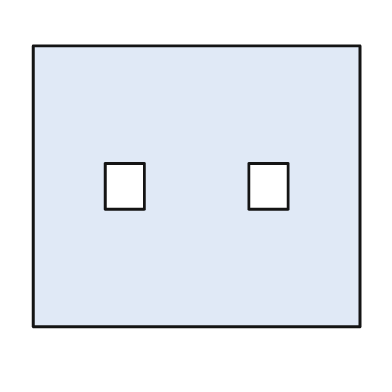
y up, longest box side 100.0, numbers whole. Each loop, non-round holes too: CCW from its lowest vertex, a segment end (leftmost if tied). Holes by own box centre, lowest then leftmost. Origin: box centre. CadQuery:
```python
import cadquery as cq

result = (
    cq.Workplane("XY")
    .moveTo(-50.0, -43.0)
    .lineTo(50.0, -43.0)
    .lineTo(50.0, 43.0)
    .lineTo(-50.0, 43.0)
    .close()
    .moveTo(-28.0, -7.0)
    .lineTo(-16.0, -7.0)
    .lineTo(-16.0, 7.0)
    .lineTo(-28.0, 7.0)
    .close()
    .moveTo(16.0, -7.0)
    .lineTo(28.0, -7.0)
    .lineTo(28.0, 7.0)
    .lineTo(16.0, 7.0)
    .close()
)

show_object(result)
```